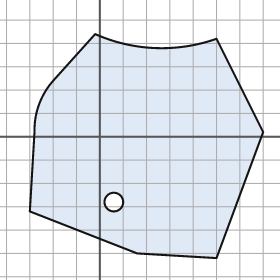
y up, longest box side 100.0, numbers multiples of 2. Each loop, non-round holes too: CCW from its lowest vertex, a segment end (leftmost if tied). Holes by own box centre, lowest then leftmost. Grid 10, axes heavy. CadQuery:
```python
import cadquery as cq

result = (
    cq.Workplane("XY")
    .moveTo(50.0, -52.0)
    .lineTo(70.0, 2.0)
    .lineTo(50.0, 42.0)
    .threePointArc((24.0, 38.0), (-2.0, 44.0))
    .lineTo(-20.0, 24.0)
    .threePointArc((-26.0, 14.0), (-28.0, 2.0))
    .lineTo(-30.0, -32.0)
    .lineTo(16.0, -50.0)
    .close()
    .moveTo(6.0, -28.0)
    .circle(4.0)
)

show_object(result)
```